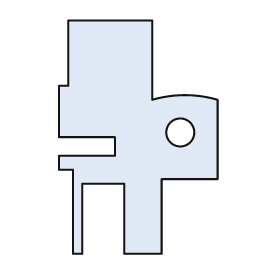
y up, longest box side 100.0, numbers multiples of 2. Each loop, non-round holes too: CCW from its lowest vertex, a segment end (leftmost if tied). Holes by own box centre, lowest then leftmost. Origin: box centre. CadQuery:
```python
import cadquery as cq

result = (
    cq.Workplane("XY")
    .moveTo(-28.0, -50.0)
    .lineTo(-24.0, -50.0)
    .lineTo(-24.0, -20.0)
    .lineTo(-6.0, -20.0)
    .lineTo(-6.0, -50.0)
    .lineTo(10.0, -50.0)
    .lineTo(10.0, -18.0)
    .lineTo(34.0, -18.0)
    .lineTo(34.0, 16.0)
    .threePointArc((20.0, 18.0), (6.0, 16.0))
    .lineTo(6.0, 50.0)
    .lineTo(-30.0, 50.0)
    .lineTo(-30.0, 22.0)
    .lineTo(-34.0, 22.0)
    .lineTo(-34.0, 0.0)
    .lineTo(-10.0, 0.0)
    .lineTo(-10.0, -8.0)
    .lineTo(-34.0, -8.0)
    .lineTo(-34.0, -14.0)
    .lineTo(-28.0, -14.0)
    .close()
    .moveTo(18.0, 2.0)
    .circle(6.0)
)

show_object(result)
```